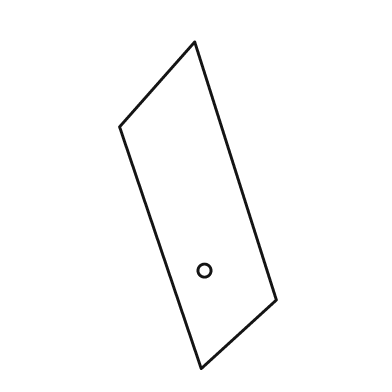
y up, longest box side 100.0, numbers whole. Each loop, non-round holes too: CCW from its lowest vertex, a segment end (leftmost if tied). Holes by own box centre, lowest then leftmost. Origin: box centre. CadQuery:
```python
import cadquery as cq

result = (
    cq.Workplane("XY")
    .moveTo(1.0, -50.0)
    .lineTo(24.0, -29.0)
    .lineTo(-1.0, 50.0)
    .lineTo(-24.0, 24.0)
    .close()
    .moveTo(2.0, -20.0)
    .circle(2.0)
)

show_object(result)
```